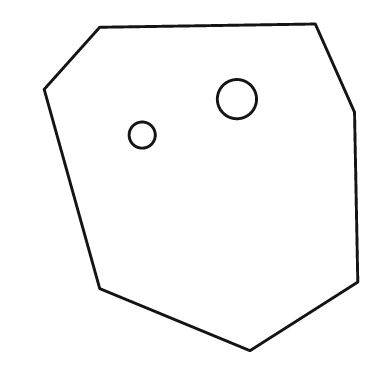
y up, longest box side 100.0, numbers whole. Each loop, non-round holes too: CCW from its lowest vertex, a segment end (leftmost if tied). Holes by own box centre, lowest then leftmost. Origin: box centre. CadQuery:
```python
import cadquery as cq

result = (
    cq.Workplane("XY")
    .moveTo(15.0, -50.0)
    .lineTo(48.0, -29.0)
    .lineTo(47.0, 23.0)
    .lineTo(35.0, 50.0)
    .lineTo(-31.0, 49.0)
    .lineTo(-48.0, 30.0)
    .lineTo(-31.0, -31.0)
    .close()
    .moveTo(-18.0, 16.0)
    .circle(4.0)
    .moveTo(11.0, 27.0)
    .circle(6.0)
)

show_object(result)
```